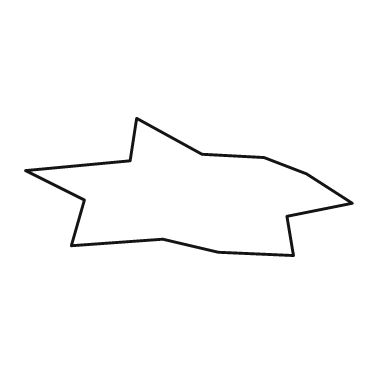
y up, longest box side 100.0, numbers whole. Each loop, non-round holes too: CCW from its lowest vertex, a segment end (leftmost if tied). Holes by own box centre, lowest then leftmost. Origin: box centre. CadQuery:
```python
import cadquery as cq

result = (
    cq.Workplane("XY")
    .moveTo(32.0, -21.0)
    .lineTo(30.0, -9.0)
    .lineTo(50.0, -5.0)
    .lineTo(36.0, 4.0)
    .lineTo(23.0, 9.0)
    .lineTo(4.0, 10.0)
    .lineTo(-16.0, 21.0)
    .lineTo(-18.0, 8.0)
    .lineTo(-50.0, 5.0)
    .lineTo(-32.0, -4.0)
    .lineTo(-36.0, -18.0)
    .lineTo(-8.0, -16.0)
    .lineTo(9.0, -20.0)
    .close()
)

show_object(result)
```